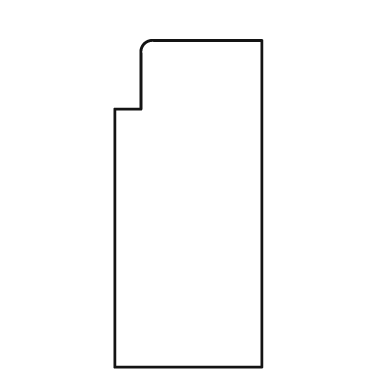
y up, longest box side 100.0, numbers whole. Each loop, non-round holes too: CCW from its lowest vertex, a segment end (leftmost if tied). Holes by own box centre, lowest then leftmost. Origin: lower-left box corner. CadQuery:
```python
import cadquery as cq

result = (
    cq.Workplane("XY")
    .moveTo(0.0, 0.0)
    .lineTo(45.0, 0.0)
    .lineTo(45.0, 100.0)
    .lineTo(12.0, 100.0)
    .threePointArc((9.0, 99.0), (8.0, 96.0))
    .lineTo(8.0, 79.0)
    .lineTo(0.0, 79.0)
    .close()
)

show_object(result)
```